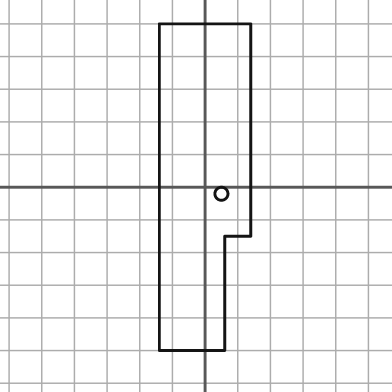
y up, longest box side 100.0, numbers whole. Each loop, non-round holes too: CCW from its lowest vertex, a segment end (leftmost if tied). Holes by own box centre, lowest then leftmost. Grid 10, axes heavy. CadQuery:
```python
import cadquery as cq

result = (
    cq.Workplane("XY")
    .moveTo(-14.0, -50.0)
    .lineTo(6.0, -50.0)
    .lineTo(6.0, -15.0)
    .lineTo(14.0, -15.0)
    .lineTo(14.0, 50.0)
    .lineTo(-14.0, 50.0)
    .close()
    .moveTo(5.0, -2.0)
    .circle(2.0)
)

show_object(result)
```